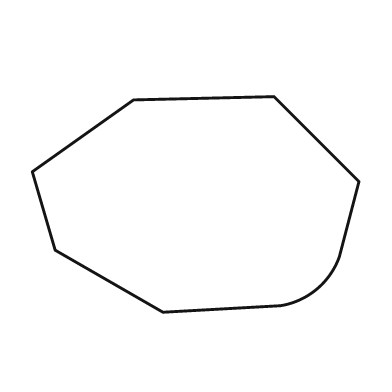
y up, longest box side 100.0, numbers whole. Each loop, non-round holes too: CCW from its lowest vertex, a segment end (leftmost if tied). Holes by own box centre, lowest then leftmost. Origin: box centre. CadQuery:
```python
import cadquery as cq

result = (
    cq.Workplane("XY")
    .moveTo(-10.0, -33.0)
    .lineTo(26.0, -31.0)
    .threePointArc((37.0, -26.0), (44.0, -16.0))
    .lineTo(50.0, 7.0)
    .lineTo(24.0, 33.0)
    .lineTo(-19.0, 32.0)
    .lineTo(-50.0, 10.0)
    .lineTo(-43.0, -14.0)
    .close()
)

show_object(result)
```